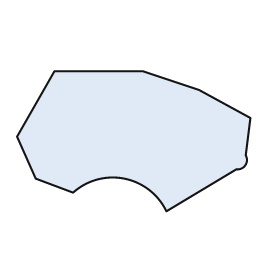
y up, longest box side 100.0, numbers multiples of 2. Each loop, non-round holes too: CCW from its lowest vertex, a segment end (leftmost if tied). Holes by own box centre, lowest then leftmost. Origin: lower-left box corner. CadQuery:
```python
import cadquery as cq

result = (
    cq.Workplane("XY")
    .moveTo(64.0, 0.0)
    .lineTo(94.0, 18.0)
    .threePointArc((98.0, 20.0), (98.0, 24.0))
    .lineTo(100.0, 40.0)
    .lineTo(78.0, 52.0)
    .lineTo(54.0, 60.0)
    .lineTo(16.0, 60.0)
    .lineTo(0.0, 32.0)
    .lineTo(8.0, 14.0)
    .lineTo(24.0, 8.0)
    .threePointArc((46.0, 14.0), (64.0, 0.0))
    .close()
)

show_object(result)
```